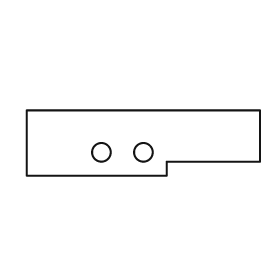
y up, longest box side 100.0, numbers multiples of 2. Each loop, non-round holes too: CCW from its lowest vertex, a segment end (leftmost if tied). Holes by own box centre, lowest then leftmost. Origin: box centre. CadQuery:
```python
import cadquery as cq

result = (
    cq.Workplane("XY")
    .moveTo(-50.0, -14.0)
    .lineTo(10.0, -14.0)
    .lineTo(10.0, -8.0)
    .lineTo(50.0, -8.0)
    .lineTo(50.0, 14.0)
    .lineTo(-50.0, 14.0)
    .close()
    .moveTo(-18.0, -4.0)
    .circle(4.0)
    .moveTo(0.0, -4.0)
    .circle(4.0)
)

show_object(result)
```